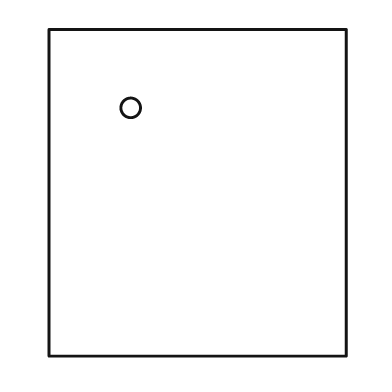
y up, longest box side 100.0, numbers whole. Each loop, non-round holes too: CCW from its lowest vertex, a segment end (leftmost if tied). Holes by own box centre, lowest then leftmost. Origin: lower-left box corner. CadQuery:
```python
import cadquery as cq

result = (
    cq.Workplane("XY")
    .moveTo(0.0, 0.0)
    .lineTo(91.0, 0.0)
    .lineTo(91.0, 100.0)
    .lineTo(0.0, 100.0)
    .close()
    .moveTo(25.0, 76.0)
    .circle(3.0)
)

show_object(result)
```